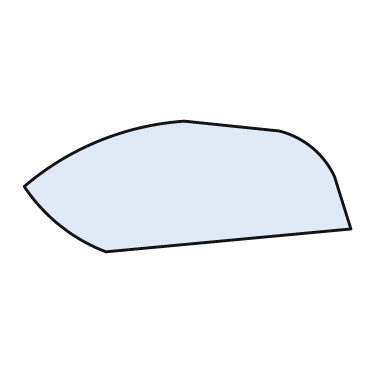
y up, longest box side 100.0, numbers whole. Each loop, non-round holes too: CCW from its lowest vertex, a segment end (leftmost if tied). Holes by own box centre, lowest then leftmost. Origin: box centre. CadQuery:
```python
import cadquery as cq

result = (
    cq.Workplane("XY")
    .moveTo(-25.0, -20.0)
    .lineTo(50.0, -13.0)
    .lineTo(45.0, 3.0)
    .threePointArc((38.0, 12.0), (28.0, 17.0))
    .lineTo(-1.0, 20.0)
    .threePointArc((-27.0, 14.0), (-50.0, 0.0))
    .threePointArc((-39.0, -12.0), (-25.0, -20.0))
    .close()
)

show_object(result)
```